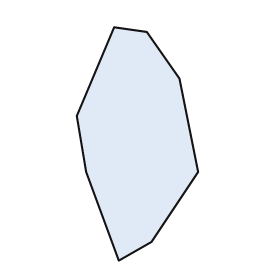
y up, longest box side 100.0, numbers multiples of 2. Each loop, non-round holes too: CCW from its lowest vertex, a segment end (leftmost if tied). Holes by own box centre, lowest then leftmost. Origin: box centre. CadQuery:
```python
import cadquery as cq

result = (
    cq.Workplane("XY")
    .moveTo(-8.0, -50.0)
    .lineTo(6.0, -42.0)
    .lineTo(26.0, -12.0)
    .lineTo(18.0, 28.0)
    .lineTo(4.0, 48.0)
    .lineTo(-10.0, 50.0)
    .lineTo(-26.0, 12.0)
    .lineTo(-22.0, -12.0)
    .close()
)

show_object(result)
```